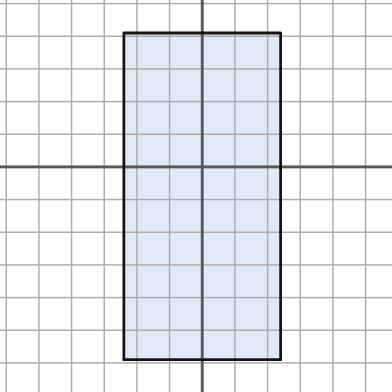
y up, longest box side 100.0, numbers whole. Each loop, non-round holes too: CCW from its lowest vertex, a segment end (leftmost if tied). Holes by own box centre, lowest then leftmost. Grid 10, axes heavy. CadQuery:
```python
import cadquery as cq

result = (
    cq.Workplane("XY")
    .moveTo(-24.0, -59.0)
    .lineTo(24.0, -59.0)
    .lineTo(24.0, 41.0)
    .lineTo(-24.0, 41.0)
    .close()
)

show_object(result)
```